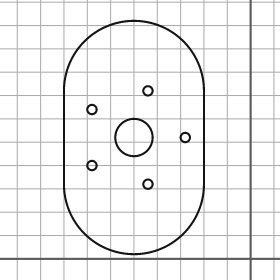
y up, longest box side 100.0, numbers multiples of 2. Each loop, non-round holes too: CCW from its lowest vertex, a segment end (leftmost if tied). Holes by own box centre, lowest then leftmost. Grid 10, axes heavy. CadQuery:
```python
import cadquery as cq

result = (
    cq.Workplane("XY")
    .moveTo(-80.0, 32.0)
    .threePointArc((-50.0, 2.0), (-20.0, 32.0))
    .lineTo(-20.0, 72.0)
    .threePointArc((-50.0, 102.0), (-80.0, 72.0))
    .close()
    .moveTo(-44.0, 32.0)
    .circle(2.0)
    .moveTo(-68.0, 40.0)
    .circle(2.0)
    .moveTo(-50.0, 52.0)
    .circle(8.0)
    .moveTo(-28.0, 52.0)
    .circle(2.0)
    .moveTo(-68.0, 64.0)
    .circle(2.0)
    .moveTo(-44.0, 72.0)
    .circle(2.0)
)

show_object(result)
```